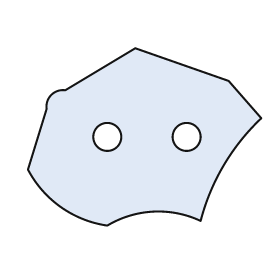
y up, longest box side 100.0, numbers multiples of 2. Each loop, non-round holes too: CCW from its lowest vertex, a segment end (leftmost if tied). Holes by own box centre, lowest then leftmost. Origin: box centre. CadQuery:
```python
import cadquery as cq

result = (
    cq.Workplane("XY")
    .moveTo(-16.0, -38.0)
    .threePointArc((4.0, -32.0), (24.0, -36.0))
    .threePointArc((34.0, -12.0), (50.0, 8.0))
    .lineTo(36.0, 24.0)
    .lineTo(-4.0, 38.0)
    .lineTo(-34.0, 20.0)
    .threePointArc((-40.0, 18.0), (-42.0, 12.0))
    .lineTo(-50.0, -14.0)
    .threePointArc((-36.0, -30.0), (-16.0, -38.0))
    .close()
    .moveTo(-16.0, 0.0)
    .circle(6.0)
    .moveTo(18.0, 0.0)
    .circle(6.0)
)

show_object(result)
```